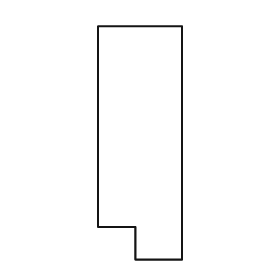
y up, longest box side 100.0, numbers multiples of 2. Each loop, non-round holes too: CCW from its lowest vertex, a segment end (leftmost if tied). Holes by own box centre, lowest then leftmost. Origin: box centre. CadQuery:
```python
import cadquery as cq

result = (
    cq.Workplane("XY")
    .moveTo(-2.0, -50.0)
    .lineTo(18.0, -50.0)
    .lineTo(18.0, 50.0)
    .lineTo(-18.0, 50.0)
    .lineTo(-18.0, -36.0)
    .lineTo(-2.0, -36.0)
    .close()
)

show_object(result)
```